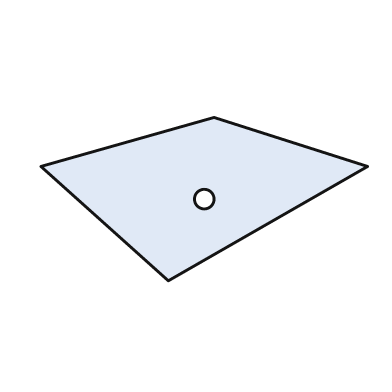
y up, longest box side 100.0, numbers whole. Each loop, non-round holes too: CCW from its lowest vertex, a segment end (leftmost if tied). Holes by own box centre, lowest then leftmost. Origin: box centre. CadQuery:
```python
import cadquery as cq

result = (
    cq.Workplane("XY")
    .moveTo(-11.0, -25.0)
    .lineTo(50.0, 10.0)
    .lineTo(3.0, 25.0)
    .lineTo(-50.0, 10.0)
    .close()
    .moveTo(0.0, 0.0)
    .circle(3.0)
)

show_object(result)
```